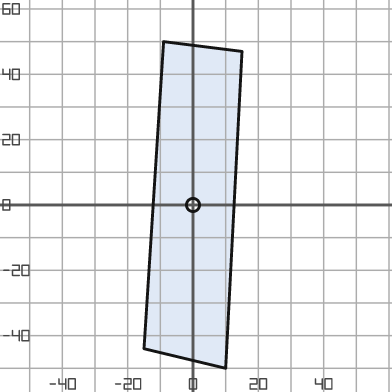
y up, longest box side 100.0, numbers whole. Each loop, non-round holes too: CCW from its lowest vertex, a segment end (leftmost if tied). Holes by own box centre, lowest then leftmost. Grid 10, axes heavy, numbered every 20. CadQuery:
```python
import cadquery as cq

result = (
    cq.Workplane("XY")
    .moveTo(10.0, -50.0)
    .lineTo(15.0, 47.0)
    .lineTo(-9.0, 50.0)
    .lineTo(-15.0, -44.0)
    .close()
    .moveTo(0.0, 0.0)
    .circle(2.0)
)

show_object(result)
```